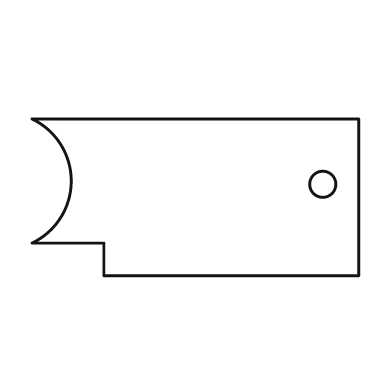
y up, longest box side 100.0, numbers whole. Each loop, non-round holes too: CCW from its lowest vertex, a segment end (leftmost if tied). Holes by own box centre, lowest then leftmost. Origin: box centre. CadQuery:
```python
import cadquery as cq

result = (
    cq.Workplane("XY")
    .moveTo(-28.0, -24.0)
    .lineTo(50.0, -24.0)
    .lineTo(50.0, 24.0)
    .lineTo(-50.0, 24.0)
    .threePointArc((-38.0, 5.0), (-50.0, -14.0))
    .lineTo(-28.0, -14.0)
    .close()
    .moveTo(39.0, 4.0)
    .circle(4.0)
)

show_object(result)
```